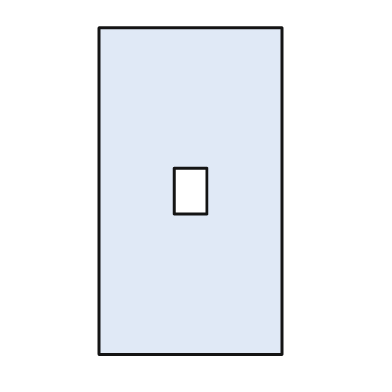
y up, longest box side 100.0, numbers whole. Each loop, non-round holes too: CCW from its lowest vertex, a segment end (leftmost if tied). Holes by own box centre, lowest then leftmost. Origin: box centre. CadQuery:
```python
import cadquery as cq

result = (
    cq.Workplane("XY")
    .moveTo(-28.0, -50.0)
    .lineTo(28.0, -50.0)
    .lineTo(28.0, 50.0)
    .lineTo(-28.0, 50.0)
    .close()
    .moveTo(-5.0, -7.0)
    .lineTo(5.0, -7.0)
    .lineTo(5.0, 7.0)
    .lineTo(-5.0, 7.0)
    .close()
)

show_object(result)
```